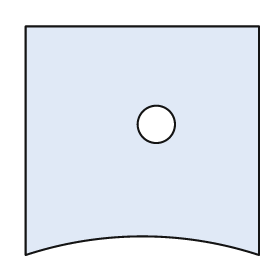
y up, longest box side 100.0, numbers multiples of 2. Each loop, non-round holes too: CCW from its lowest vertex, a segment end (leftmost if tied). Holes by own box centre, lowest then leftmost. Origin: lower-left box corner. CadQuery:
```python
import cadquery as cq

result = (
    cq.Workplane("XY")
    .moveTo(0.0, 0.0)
    .threePointArc((50.0, 8.0), (100.0, 0.0))
    .lineTo(100.0, 98.0)
    .lineTo(0.0, 98.0)
    .close()
    .moveTo(56.0, 56.0)
    .circle(8.0)
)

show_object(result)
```